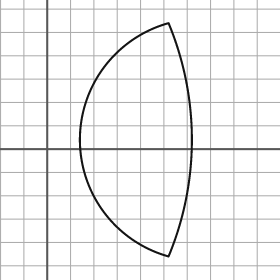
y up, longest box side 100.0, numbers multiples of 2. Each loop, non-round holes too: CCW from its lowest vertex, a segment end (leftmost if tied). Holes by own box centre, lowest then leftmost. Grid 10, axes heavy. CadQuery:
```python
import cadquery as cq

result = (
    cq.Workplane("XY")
    .moveTo(52.0, -46.0)
    .threePointArc((62.0, 4.0), (52.0, 54.0))
    .threePointArc((14.0, 4.0), (52.0, -46.0))
    .close()
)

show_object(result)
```